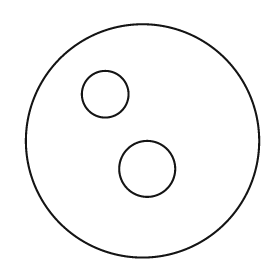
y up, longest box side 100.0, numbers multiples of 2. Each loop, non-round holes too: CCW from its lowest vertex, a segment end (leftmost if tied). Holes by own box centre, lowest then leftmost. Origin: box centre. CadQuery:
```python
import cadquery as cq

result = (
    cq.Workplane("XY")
    .moveTo(0.0, 0.0)
    .circle(50.0)
    .moveTo(2.0, -12.0)
    .circle(12.0)
    .moveTo(-16.0, 20.0)
    .circle(10.0)
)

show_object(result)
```